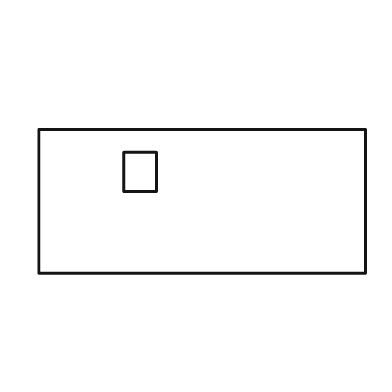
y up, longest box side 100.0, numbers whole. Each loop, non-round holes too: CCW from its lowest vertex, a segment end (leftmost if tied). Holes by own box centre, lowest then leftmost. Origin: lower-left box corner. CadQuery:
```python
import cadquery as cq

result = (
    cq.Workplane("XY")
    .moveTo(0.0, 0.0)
    .lineTo(100.0, 0.0)
    .lineTo(100.0, 44.0)
    .lineTo(0.0, 44.0)
    .close()
    .moveTo(26.0, 25.0)
    .lineTo(36.0, 25.0)
    .lineTo(36.0, 37.0)
    .lineTo(26.0, 37.0)
    .close()
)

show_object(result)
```